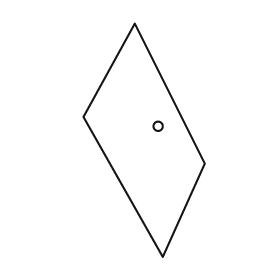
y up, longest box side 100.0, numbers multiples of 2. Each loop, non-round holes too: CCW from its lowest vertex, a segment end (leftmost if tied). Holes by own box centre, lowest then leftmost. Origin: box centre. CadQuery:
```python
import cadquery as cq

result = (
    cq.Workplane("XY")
    .moveTo(8.0, -50.0)
    .lineTo(26.0, -10.0)
    .lineTo(-4.0, 50.0)
    .lineTo(-26.0, 10.0)
    .close()
    .moveTo(6.0, 6.0)
    .circle(2.0)
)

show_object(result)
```